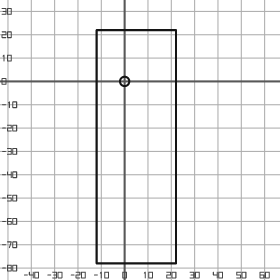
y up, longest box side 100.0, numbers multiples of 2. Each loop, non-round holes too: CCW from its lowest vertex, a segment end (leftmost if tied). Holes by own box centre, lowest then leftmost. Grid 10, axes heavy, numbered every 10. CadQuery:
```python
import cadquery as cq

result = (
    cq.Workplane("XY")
    .moveTo(-12.0, -78.0)
    .lineTo(22.0, -78.0)
    .lineTo(22.0, 22.0)
    .lineTo(-12.0, 22.0)
    .close()
    .moveTo(0.0, 0.0)
    .circle(2.0)
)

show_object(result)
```